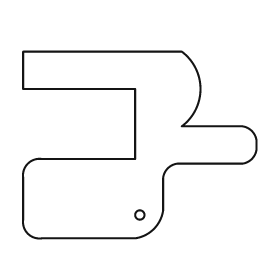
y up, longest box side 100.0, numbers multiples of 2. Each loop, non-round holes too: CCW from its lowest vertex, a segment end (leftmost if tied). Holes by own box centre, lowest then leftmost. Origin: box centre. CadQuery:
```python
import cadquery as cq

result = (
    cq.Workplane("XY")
    .moveTo(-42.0, -40.0)
    .lineTo(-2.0, -40.0)
    .threePointArc((6.0, -36.0), (10.0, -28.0))
    .lineTo(10.0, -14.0)
    .threePointArc((12.0, -10.0), (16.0, -8.0))
    .lineTo(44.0, -8.0)
    .threePointArc((48.0, -6.0), (50.0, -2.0))
    .lineTo(50.0, 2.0)
    .threePointArc((48.0, 6.0), (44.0, 8.0))
    .lineTo(18.0, 8.0)
    .threePointArc((26.0, 24.0), (18.0, 40.0))
    .lineTo(-50.0, 40.0)
    .lineTo(-50.0, 24.0)
    .lineTo(-2.0, 24.0)
    .lineTo(-2.0, -6.0)
    .lineTo(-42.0, -6.0)
    .threePointArc((-48.0, -8.0), (-50.0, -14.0))
    .lineTo(-50.0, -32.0)
    .threePointArc((-48.0, -38.0), (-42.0, -40.0))
    .close()
    .moveTo(0.0, -30.0)
    .circle(2.0)
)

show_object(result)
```